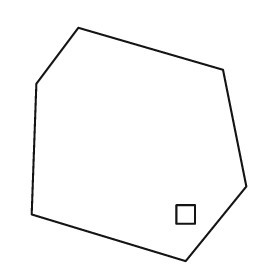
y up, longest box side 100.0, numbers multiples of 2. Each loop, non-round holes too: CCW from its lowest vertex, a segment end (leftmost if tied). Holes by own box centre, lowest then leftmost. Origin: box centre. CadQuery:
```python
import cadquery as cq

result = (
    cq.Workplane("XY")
    .moveTo(20.0, -50.0)
    .lineTo(46.0, -18.0)
    .lineTo(36.0, 32.0)
    .lineTo(-26.0, 50.0)
    .lineTo(-44.0, 26.0)
    .lineTo(-46.0, -30.0)
    .close()
    .moveTo(16.0, -34.0)
    .lineTo(24.0, -34.0)
    .lineTo(24.0, -26.0)
    .lineTo(16.0, -26.0)
    .close()
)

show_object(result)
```